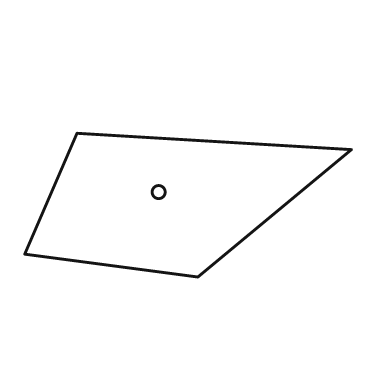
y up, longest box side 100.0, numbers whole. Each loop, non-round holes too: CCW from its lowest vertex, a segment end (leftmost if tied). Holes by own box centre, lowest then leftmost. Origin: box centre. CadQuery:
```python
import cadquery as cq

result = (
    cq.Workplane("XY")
    .moveTo(3.0, -22.0)
    .lineTo(50.0, 17.0)
    .lineTo(-34.0, 22.0)
    .lineTo(-50.0, -15.0)
    .close()
    .moveTo(-9.0, 4.0)
    .circle(2.0)
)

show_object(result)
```